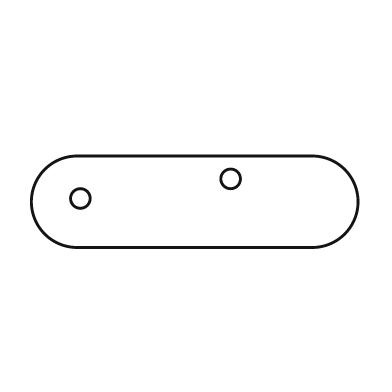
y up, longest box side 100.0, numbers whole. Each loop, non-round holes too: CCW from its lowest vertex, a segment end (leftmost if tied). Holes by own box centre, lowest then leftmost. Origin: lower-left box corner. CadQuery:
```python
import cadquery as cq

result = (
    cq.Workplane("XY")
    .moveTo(14.0, 0.0)
    .lineTo(86.0, 0.0)
    .threePointArc((100.0, 14.0), (86.0, 28.0))
    .lineTo(14.0, 28.0)
    .threePointArc((0.0, 14.0), (14.0, 0.0))
    .close()
    .moveTo(15.0, 15.0)
    .circle(3.0)
    .moveTo(61.0, 21.0)
    .circle(3.0)
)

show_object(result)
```